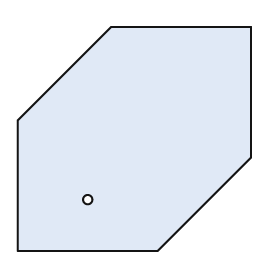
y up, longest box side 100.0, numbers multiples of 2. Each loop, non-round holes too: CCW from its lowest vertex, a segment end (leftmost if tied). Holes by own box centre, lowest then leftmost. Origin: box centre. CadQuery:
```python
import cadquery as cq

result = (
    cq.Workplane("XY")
    .moveTo(-50.0, -48.0)
    .lineTo(10.0, -48.0)
    .lineTo(50.0, -8.0)
    .lineTo(50.0, 48.0)
    .lineTo(-10.0, 48.0)
    .lineTo(-50.0, 8.0)
    .close()
    .moveTo(-20.0, -26.0)
    .circle(2.0)
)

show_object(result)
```